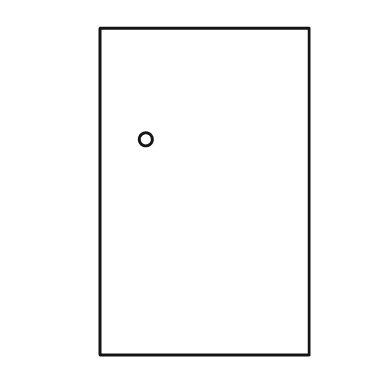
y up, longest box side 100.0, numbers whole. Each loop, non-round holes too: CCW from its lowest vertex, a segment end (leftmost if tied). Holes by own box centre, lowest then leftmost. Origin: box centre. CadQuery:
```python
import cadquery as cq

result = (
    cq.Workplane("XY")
    .moveTo(-32.0, -50.0)
    .lineTo(32.0, -50.0)
    .lineTo(32.0, 50.0)
    .lineTo(-32.0, 50.0)
    .close()
    .moveTo(-18.0, 16.0)
    .circle(2.0)
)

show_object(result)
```